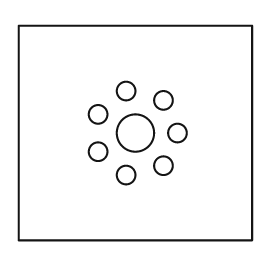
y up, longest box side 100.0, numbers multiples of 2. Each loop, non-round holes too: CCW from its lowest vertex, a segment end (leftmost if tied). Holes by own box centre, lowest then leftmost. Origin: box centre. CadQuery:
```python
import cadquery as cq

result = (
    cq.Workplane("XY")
    .moveTo(-50.0, -46.0)
    .lineTo(50.0, -46.0)
    .lineTo(50.0, 46.0)
    .lineTo(-50.0, 46.0)
    .close()
    .moveTo(-4.0, -18.0)
    .circle(4.0)
    .moveTo(12.0, -14.0)
    .circle(4.0)
    .moveTo(-16.0, -8.0)
    .circle(4.0)
    .moveTo(0.0, 0.0)
    .circle(8.0)
    .moveTo(18.0, 0.0)
    .circle(4.0)
    .moveTo(-16.0, 8.0)
    .circle(4.0)
    .moveTo(12.0, 14.0)
    .circle(4.0)
    .moveTo(-4.0, 18.0)
    .circle(4.0)
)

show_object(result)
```